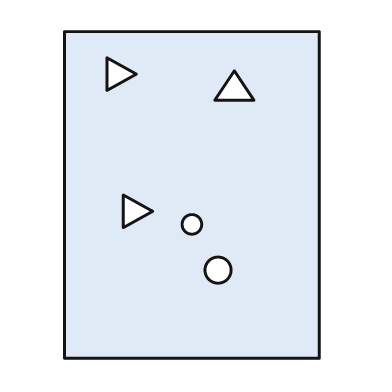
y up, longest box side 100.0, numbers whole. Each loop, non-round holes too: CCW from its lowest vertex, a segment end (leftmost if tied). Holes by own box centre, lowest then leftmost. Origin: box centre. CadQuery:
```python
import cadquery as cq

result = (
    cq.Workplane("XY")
    .moveTo(-39.0, -50.0)
    .lineTo(39.0, -50.0)
    .lineTo(39.0, 50.0)
    .lineTo(-39.0, 50.0)
    .close()
    .moveTo(8.0, -23.0)
    .circle(4.0)
    .moveTo(0.0, -9.0)
    .circle(3.0)
    .moveTo(-21.0, -10.0)
    .lineTo(-12.0, -5.0)
    .lineTo(-21.0, 0.0)
    .close()
    .moveTo(7.0, 29.0)
    .lineTo(19.0, 29.0)
    .lineTo(13.0, 38.0)
    .close()
    .moveTo(-26.0, 32.0)
    .lineTo(-17.0, 37.0)
    .lineTo(-26.0, 42.0)
    .close()
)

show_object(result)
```